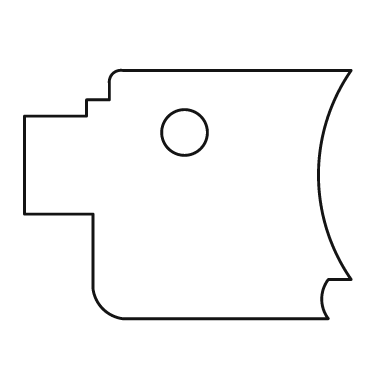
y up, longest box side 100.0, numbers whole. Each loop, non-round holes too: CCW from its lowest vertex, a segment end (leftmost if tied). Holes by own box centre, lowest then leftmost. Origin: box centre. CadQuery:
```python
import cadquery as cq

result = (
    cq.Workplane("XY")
    .moveTo(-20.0, -38.0)
    .lineTo(43.0, -38.0)
    .threePointArc((41.0, -32.0), (43.0, -26.0))
    .lineTo(50.0, -26.0)
    .threePointArc((40.0, 6.0), (50.0, 38.0))
    .lineTo(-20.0, 38.0)
    .threePointArc((-23.0, 37.0), (-24.0, 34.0))
    .lineTo(-24.0, 29.0)
    .lineTo(-31.0, 29.0)
    .lineTo(-31.0, 24.0)
    .lineTo(-50.0, 24.0)
    .lineTo(-50.0, -6.0)
    .lineTo(-29.0, -6.0)
    .lineTo(-29.0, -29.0)
    .threePointArc((-26.0, -35.0), (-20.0, -38.0))
    .close()
    .moveTo(-1.0, 19.0)
    .circle(7.0)
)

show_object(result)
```